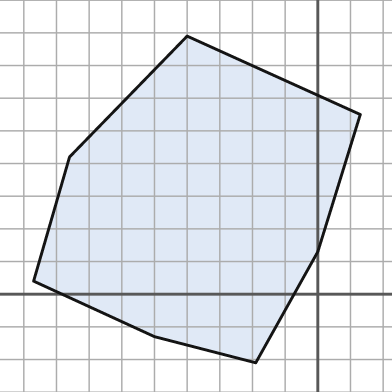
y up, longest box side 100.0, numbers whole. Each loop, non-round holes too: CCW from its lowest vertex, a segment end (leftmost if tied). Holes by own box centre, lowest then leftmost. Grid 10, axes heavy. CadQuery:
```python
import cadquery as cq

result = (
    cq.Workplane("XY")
    .moveTo(-19.0, -21.0)
    .lineTo(0.0, 13.0)
    .lineTo(13.0, 55.0)
    .lineTo(-40.0, 79.0)
    .lineTo(-76.0, 42.0)
    .lineTo(-87.0, 4.0)
    .lineTo(-50.0, -13.0)
    .close()
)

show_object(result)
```